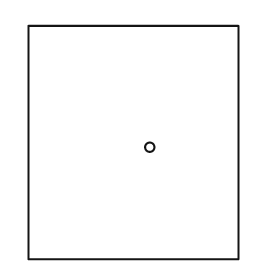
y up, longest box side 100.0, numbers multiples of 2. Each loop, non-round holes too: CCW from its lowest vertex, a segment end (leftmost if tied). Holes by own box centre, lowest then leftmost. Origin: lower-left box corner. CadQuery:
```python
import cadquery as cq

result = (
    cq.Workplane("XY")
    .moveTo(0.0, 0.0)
    .lineTo(90.0, 0.0)
    .lineTo(90.0, 100.0)
    .lineTo(0.0, 100.0)
    .close()
    .moveTo(52.0, 48.0)
    .circle(2.0)
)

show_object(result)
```